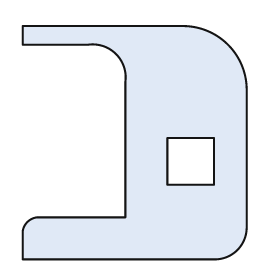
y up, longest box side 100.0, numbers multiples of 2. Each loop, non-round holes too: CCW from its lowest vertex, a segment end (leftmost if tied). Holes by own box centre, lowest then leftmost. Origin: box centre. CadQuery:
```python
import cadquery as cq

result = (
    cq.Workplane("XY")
    .moveTo(-48.0, -50.0)
    .lineTo(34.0, -50.0)
    .threePointArc((44.0, -46.0), (48.0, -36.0))
    .lineTo(48.0, 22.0)
    .threePointArc((40.0, 42.0), (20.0, 50.0))
    .lineTo(-48.0, 50.0)
    .lineTo(-48.0, 42.0)
    .lineTo(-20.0, 42.0)
    .threePointArc((-8.0, 38.0), (-4.0, 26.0))
    .lineTo(-4.0, -32.0)
    .lineTo(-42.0, -32.0)
    .threePointArc((-46.0, -34.0), (-48.0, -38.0))
    .close()
    .moveTo(14.0, -18.0)
    .lineTo(34.0, -18.0)
    .lineTo(34.0, 2.0)
    .lineTo(14.0, 2.0)
    .close()
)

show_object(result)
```